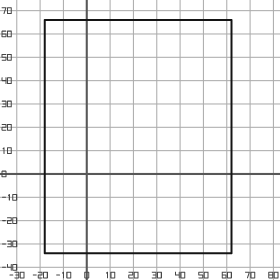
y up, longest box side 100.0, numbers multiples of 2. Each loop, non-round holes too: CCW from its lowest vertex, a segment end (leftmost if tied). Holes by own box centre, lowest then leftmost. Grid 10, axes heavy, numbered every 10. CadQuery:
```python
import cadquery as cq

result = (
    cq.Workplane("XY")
    .moveTo(-18.0, -34.0)
    .lineTo(62.0, -34.0)
    .lineTo(62.0, 66.0)
    .lineTo(-18.0, 66.0)
    .close()
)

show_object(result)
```